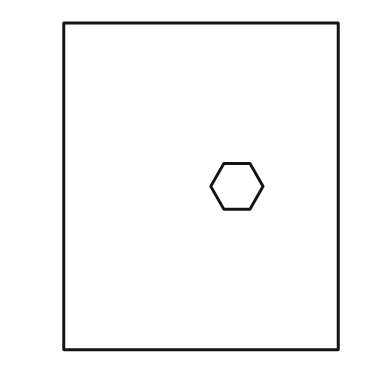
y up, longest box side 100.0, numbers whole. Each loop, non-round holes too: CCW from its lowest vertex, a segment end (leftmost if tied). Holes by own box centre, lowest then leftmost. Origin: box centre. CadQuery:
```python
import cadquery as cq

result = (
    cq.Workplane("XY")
    .moveTo(-42.0, -50.0)
    .lineTo(42.0, -50.0)
    .lineTo(42.0, 50.0)
    .lineTo(-42.0, 50.0)
    .close()
    .moveTo(7.0, -7.0)
    .lineTo(15.0, -7.0)
    .lineTo(19.0, 0.0)
    .lineTo(15.0, 7.0)
    .lineTo(7.0, 7.0)
    .lineTo(3.0, 0.0)
    .close()
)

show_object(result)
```